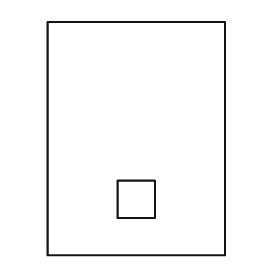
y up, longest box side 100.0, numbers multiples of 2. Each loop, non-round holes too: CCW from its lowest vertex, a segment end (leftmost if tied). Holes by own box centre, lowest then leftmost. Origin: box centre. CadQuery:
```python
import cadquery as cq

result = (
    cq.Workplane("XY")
    .moveTo(-38.0, -50.0)
    .lineTo(38.0, -50.0)
    .lineTo(38.0, 50.0)
    .lineTo(-38.0, 50.0)
    .close()
    .moveTo(-8.0, -34.0)
    .lineTo(8.0, -34.0)
    .lineTo(8.0, -18.0)
    .lineTo(-8.0, -18.0)
    .close()
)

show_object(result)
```